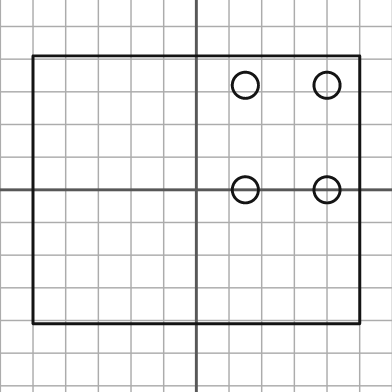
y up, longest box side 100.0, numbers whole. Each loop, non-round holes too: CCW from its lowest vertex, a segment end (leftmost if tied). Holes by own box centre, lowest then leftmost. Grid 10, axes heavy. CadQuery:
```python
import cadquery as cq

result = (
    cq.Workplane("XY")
    .moveTo(-50.0, -41.0)
    .lineTo(50.0, -41.0)
    .lineTo(50.0, 41.0)
    .lineTo(-50.0, 41.0)
    .close()
    .moveTo(15.0, 0.0)
    .circle(4.0)
    .moveTo(40.0, 0.0)
    .circle(4.0)
    .moveTo(15.0, 32.0)
    .circle(4.0)
    .moveTo(40.0, 32.0)
    .circle(4.0)
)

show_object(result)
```